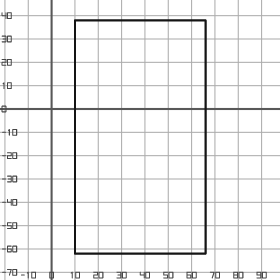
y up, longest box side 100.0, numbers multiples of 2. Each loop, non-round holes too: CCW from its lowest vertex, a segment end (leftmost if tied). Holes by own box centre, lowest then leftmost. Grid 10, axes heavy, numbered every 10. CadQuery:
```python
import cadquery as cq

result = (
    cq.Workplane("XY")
    .moveTo(10.0, -62.0)
    .lineTo(66.0, -62.0)
    .lineTo(66.0, 38.0)
    .lineTo(10.0, 38.0)
    .close()
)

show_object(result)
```